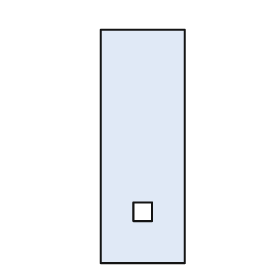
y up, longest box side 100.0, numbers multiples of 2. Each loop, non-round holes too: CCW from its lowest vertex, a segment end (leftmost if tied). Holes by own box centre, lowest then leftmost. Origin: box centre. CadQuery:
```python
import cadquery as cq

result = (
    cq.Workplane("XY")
    .moveTo(-18.0, -50.0)
    .lineTo(18.0, -50.0)
    .lineTo(18.0, 50.0)
    .lineTo(-18.0, 50.0)
    .close()
    .moveTo(-4.0, -32.0)
    .lineTo(4.0, -32.0)
    .lineTo(4.0, -24.0)
    .lineTo(-4.0, -24.0)
    .close()
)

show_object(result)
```